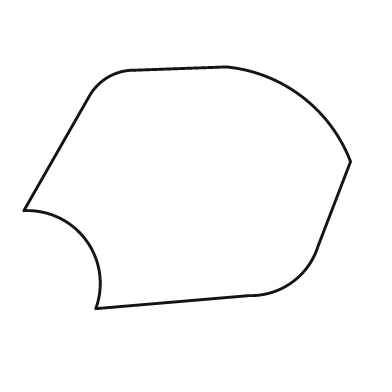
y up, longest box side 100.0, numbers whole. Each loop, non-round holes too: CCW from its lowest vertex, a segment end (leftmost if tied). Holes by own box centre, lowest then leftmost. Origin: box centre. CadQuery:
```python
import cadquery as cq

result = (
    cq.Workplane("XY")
    .moveTo(-28.0, -37.0)
    .lineTo(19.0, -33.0)
    .threePointArc((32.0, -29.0), (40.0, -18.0))
    .lineTo(50.0, 8.0)
    .threePointArc((35.0, 28.0), (12.0, 37.0))
    .lineTo(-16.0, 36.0)
    .threePointArc((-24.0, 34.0), (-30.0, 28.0))
    .lineTo(-50.0, -7.0)
    .threePointArc((-31.0, -16.0), (-28.0, -37.0))
    .close()
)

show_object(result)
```